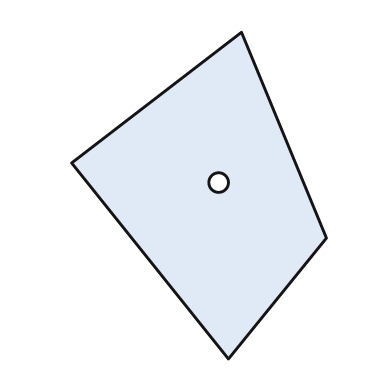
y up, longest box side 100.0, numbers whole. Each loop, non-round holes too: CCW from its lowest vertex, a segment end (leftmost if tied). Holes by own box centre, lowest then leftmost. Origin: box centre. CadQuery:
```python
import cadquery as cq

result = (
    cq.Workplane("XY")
    .moveTo(9.0, -50.0)
    .lineTo(39.0, -13.0)
    .lineTo(13.0, 50.0)
    .lineTo(-39.0, 10.0)
    .close()
    .moveTo(6.0, 4.0)
    .circle(3.0)
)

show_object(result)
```